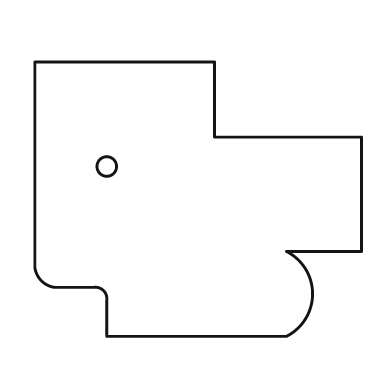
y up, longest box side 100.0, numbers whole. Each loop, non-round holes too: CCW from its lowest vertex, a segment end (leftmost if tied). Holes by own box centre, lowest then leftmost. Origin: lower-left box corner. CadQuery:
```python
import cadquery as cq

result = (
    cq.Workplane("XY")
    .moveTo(22.0, 0.0)
    .lineTo(77.0, 0.0)
    .threePointArc((85.0, 13.0), (77.0, 26.0))
    .lineTo(100.0, 26.0)
    .lineTo(100.0, 61.0)
    .lineTo(55.0, 61.0)
    .lineTo(55.0, 84.0)
    .lineTo(0.0, 84.0)
    .lineTo(0.0, 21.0)
    .threePointArc((2.0, 17.0), (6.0, 15.0))
    .lineTo(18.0, 15.0)
    .threePointArc((21.0, 14.0), (22.0, 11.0))
    .close()
    .moveTo(22.0, 52.0)
    .circle(3.0)
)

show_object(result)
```